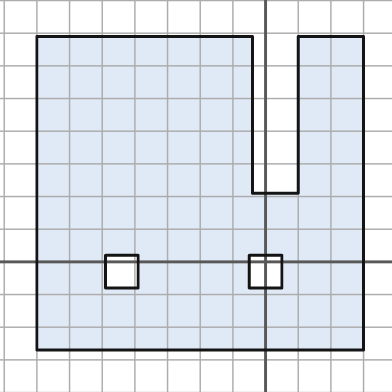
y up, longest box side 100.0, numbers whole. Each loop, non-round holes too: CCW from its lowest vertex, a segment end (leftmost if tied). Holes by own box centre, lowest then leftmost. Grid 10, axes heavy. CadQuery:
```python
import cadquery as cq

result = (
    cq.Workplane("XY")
    .moveTo(-70.0, -27.0)
    .lineTo(30.0, -27.0)
    .lineTo(30.0, 69.0)
    .lineTo(10.0, 69.0)
    .lineTo(10.0, 21.0)
    .lineTo(-4.0, 21.0)
    .lineTo(-4.0, 69.0)
    .lineTo(-70.0, 69.0)
    .close()
    .moveTo(-49.0, -8.0)
    .lineTo(-39.0, -8.0)
    .lineTo(-39.0, 2.0)
    .lineTo(-49.0, 2.0)
    .close()
    .moveTo(-5.0, -8.0)
    .lineTo(5.0, -8.0)
    .lineTo(5.0, 2.0)
    .lineTo(-5.0, 2.0)
    .close()
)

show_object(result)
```